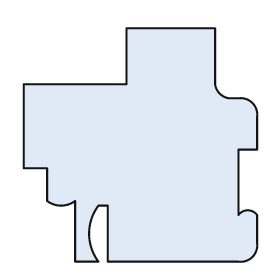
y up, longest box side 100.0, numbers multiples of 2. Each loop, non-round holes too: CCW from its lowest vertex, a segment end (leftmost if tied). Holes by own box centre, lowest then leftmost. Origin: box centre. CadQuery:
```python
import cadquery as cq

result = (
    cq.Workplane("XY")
    .moveTo(-28.0, -50.0)
    .lineTo(-18.0, -50.0)
    .threePointArc((-22.0, -38.0), (-18.0, -26.0))
    .lineTo(-14.0, -26.0)
    .lineTo(-14.0, -50.0)
    .lineTo(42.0, -50.0)
    .threePointArc((48.0, -48.0), (50.0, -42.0))
    .lineTo(50.0, -30.0)
    .threePointArc((46.0, -28.0), (42.0, -30.0))
    .lineTo(42.0, -2.0)
    .lineTo(50.0, -2.0)
    .lineTo(50.0, 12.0)
    .threePointArc((48.0, 18.0), (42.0, 20.0))
    .lineTo(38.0, 20.0)
    .threePointArc((34.0, 22.0), (32.0, 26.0))
    .lineTo(32.0, 50.0)
    .lineTo(-6.0, 50.0)
    .lineTo(-6.0, 26.0)
    .lineTo(-50.0, 26.0)
    .lineTo(-50.0, -10.0)
    .lineTo(-40.0, -10.0)
    .lineTo(-40.0, -24.0)
    .threePointArc((-34.0, -26.0), (-28.0, -24.0))
    .close()
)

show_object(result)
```